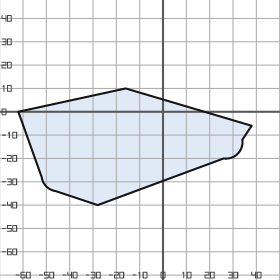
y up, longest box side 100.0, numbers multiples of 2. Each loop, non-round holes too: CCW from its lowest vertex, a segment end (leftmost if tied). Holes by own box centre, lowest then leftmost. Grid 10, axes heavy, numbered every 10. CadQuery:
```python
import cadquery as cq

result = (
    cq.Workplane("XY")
    .moveTo(-28.0, -40.0)
    .lineTo(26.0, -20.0)
    .threePointArc((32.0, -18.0), (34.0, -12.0))
    .lineTo(38.0, -6.0)
    .lineTo(-16.0, 10.0)
    .lineTo(-62.0, 0.0)
    .lineTo(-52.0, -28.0)
    .threePointArc((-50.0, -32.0), (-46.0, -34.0))
    .close()
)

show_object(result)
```